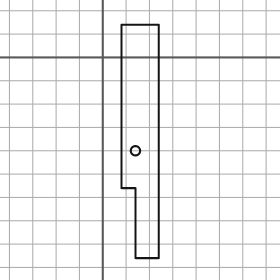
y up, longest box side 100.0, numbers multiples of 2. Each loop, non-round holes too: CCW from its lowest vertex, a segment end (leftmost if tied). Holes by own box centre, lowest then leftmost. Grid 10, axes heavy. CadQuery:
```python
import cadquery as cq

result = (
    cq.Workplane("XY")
    .moveTo(14.0, -86.0)
    .lineTo(24.0, -86.0)
    .lineTo(24.0, 14.0)
    .lineTo(8.0, 14.0)
    .lineTo(8.0, -56.0)
    .lineTo(14.0, -56.0)
    .close()
    .moveTo(14.0, -40.0)
    .circle(2.0)
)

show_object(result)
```